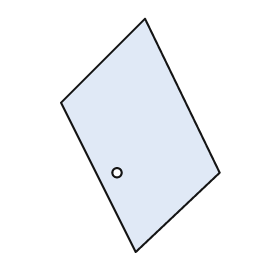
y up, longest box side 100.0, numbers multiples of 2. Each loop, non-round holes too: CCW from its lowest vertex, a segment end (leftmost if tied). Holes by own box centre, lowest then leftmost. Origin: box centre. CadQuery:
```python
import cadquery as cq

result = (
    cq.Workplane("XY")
    .moveTo(-2.0, -50.0)
    .lineTo(34.0, -16.0)
    .lineTo(2.0, 50.0)
    .lineTo(-34.0, 14.0)
    .close()
    .moveTo(-10.0, -16.0)
    .circle(2.0)
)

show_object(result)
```